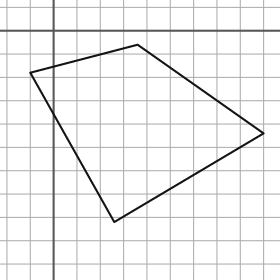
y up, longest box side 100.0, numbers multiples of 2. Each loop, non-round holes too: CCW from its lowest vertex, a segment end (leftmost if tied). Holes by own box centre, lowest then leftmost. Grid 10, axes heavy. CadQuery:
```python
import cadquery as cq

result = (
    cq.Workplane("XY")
    .moveTo(26.0, -82.0)
    .lineTo(90.0, -44.0)
    .lineTo(36.0, -6.0)
    .lineTo(-10.0, -18.0)
    .close()
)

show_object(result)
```